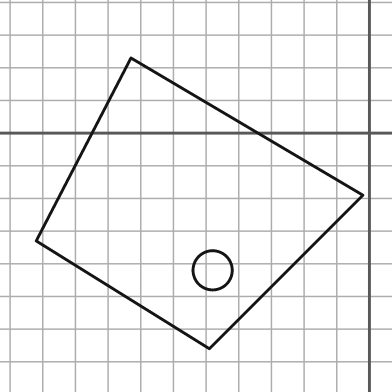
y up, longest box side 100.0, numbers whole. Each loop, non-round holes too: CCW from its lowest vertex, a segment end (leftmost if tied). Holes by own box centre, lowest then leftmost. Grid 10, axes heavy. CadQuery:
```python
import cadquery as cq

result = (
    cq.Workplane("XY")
    .moveTo(-49.0, -66.0)
    .lineTo(-2.0, -19.0)
    .lineTo(-73.0, 23.0)
    .lineTo(-102.0, -33.0)
    .close()
    .moveTo(-48.0, -42.0)
    .circle(6.0)
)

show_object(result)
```